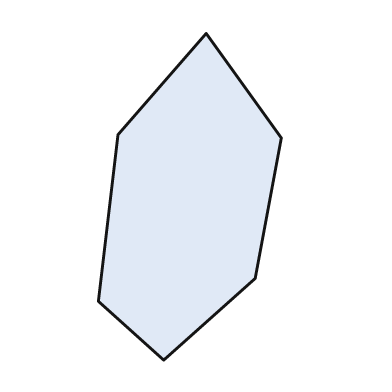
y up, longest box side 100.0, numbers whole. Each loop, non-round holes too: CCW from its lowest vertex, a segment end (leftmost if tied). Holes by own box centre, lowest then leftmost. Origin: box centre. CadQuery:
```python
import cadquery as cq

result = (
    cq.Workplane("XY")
    .moveTo(-8.0, -50.0)
    .lineTo(20.0, -25.0)
    .lineTo(28.0, 18.0)
    .lineTo(5.0, 50.0)
    .lineTo(-22.0, 19.0)
    .lineTo(-28.0, -32.0)
    .close()
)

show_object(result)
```